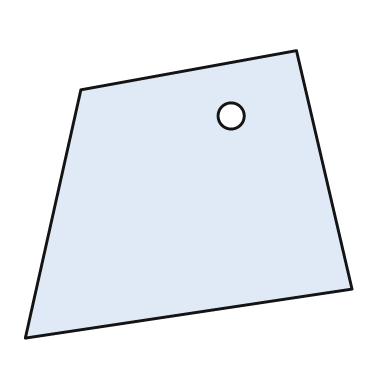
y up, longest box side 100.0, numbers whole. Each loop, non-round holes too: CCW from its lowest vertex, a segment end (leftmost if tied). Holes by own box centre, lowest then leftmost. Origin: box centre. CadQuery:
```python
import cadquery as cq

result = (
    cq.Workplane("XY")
    .moveTo(-50.0, -44.0)
    .lineTo(50.0, -29.0)
    .lineTo(33.0, 44.0)
    .lineTo(-33.0, 32.0)
    .close()
    .moveTo(13.0, 24.0)
    .circle(4.0)
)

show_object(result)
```